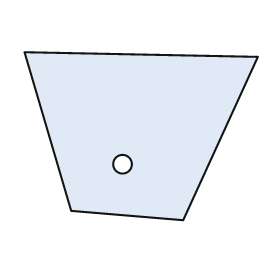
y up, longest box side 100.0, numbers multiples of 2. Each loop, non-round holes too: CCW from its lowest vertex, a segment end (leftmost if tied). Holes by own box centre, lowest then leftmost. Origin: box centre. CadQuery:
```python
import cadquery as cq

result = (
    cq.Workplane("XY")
    .moveTo(18.0, -36.0)
    .lineTo(50.0, 34.0)
    .lineTo(-50.0, 36.0)
    .lineTo(-30.0, -32.0)
    .close()
    .moveTo(-8.0, -12.0)
    .circle(4.0)
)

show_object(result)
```